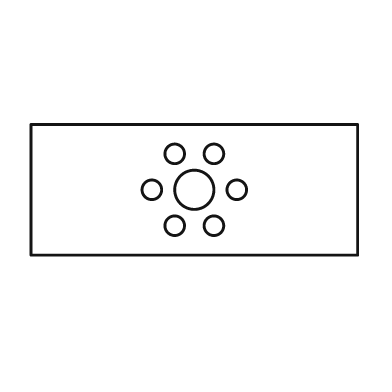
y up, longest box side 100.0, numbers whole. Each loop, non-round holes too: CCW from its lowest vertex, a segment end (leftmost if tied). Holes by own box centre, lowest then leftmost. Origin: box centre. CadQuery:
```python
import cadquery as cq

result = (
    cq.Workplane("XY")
    .moveTo(-50.0, -20.0)
    .lineTo(50.0, -20.0)
    .lineTo(50.0, 20.0)
    .lineTo(-50.0, 20.0)
    .close()
    .moveTo(-6.0, -11.0)
    .circle(3.0)
    .moveTo(6.0, -11.0)
    .circle(3.0)
    .moveTo(-13.0, 0.0)
    .circle(3.0)
    .moveTo(0.0, 0.0)
    .circle(6.0)
    .moveTo(13.0, 0.0)
    .circle(3.0)
    .moveTo(-6.0, 11.0)
    .circle(3.0)
    .moveTo(6.0, 11.0)
    .circle(3.0)
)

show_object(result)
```